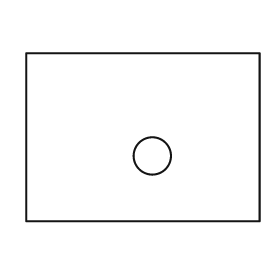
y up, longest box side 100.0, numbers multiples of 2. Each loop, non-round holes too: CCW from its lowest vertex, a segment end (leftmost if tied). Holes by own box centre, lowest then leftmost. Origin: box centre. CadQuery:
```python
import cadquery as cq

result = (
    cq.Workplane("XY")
    .moveTo(-50.0, -36.0)
    .lineTo(50.0, -36.0)
    .lineTo(50.0, 36.0)
    .lineTo(-50.0, 36.0)
    .close()
    .moveTo(4.0, -8.0)
    .circle(8.0)
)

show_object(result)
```